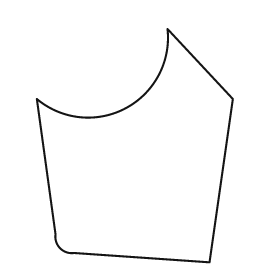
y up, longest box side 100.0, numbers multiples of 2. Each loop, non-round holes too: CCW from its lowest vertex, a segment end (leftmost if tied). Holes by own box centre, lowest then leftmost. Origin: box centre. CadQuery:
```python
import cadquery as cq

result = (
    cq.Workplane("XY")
    .moveTo(32.0, -50.0)
    .lineTo(42.0, 20.0)
    .lineTo(14.0, 50.0)
    .threePointArc((-4.0, 16.0), (-42.0, 20.0))
    .lineTo(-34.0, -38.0)
    .threePointArc((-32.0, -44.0), (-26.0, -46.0))
    .close()
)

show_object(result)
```